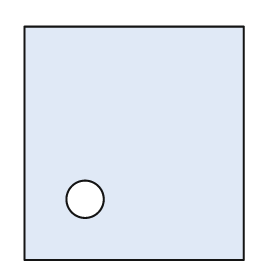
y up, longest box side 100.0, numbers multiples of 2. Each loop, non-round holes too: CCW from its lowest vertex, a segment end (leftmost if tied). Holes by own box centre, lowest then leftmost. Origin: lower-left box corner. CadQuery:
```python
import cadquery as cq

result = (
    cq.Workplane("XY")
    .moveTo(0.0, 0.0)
    .lineTo(94.0, 0.0)
    .lineTo(94.0, 100.0)
    .lineTo(0.0, 100.0)
    .close()
    .moveTo(26.0, 26.0)
    .circle(8.0)
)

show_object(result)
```